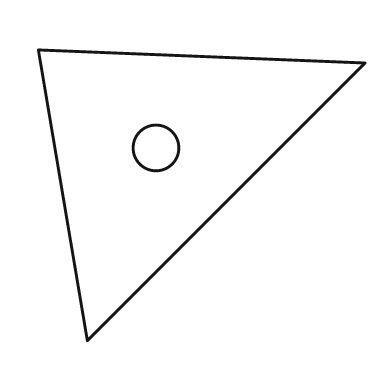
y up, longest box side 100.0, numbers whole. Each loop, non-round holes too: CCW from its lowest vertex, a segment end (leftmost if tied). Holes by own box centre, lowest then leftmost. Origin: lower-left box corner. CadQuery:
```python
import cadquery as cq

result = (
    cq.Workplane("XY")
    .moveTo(15.0, 0.0)
    .lineTo(100.0, 85.0)
    .lineTo(0.0, 89.0)
    .close()
    .moveTo(36.0, 59.0)
    .circle(7.0)
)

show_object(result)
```